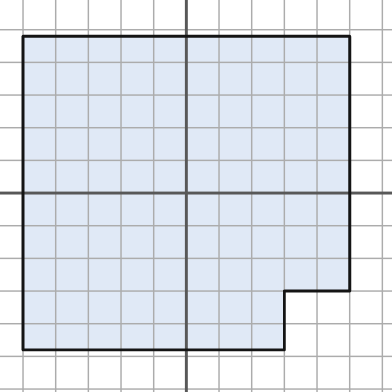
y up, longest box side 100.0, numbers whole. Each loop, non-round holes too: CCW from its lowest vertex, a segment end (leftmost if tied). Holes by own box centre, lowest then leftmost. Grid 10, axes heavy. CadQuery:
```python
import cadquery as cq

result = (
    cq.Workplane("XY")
    .moveTo(-50.0, -48.0)
    .lineTo(30.0, -48.0)
    .lineTo(30.0, -30.0)
    .lineTo(50.0, -30.0)
    .lineTo(50.0, 48.0)
    .lineTo(-50.0, 48.0)
    .close()
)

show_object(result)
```